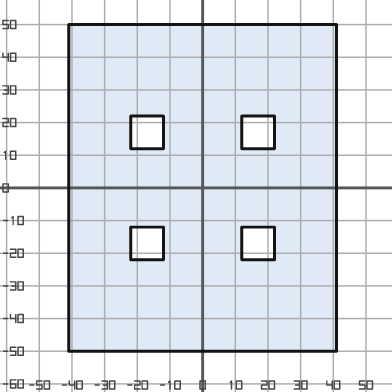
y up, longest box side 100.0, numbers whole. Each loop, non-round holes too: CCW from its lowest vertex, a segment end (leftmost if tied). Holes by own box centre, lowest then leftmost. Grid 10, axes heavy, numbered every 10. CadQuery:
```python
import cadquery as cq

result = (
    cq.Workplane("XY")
    .moveTo(-41.0, -50.0)
    .lineTo(41.0, -50.0)
    .lineTo(41.0, 50.0)
    .lineTo(-41.0, 50.0)
    .close()
    .moveTo(-22.0, -22.0)
    .lineTo(-12.0, -22.0)
    .lineTo(-12.0, -12.0)
    .lineTo(-22.0, -12.0)
    .close()
    .moveTo(12.0, -22.0)
    .lineTo(22.0, -22.0)
    .lineTo(22.0, -12.0)
    .lineTo(12.0, -12.0)
    .close()
    .moveTo(-22.0, 12.0)
    .lineTo(-12.0, 12.0)
    .lineTo(-12.0, 22.0)
    .lineTo(-22.0, 22.0)
    .close()
    .moveTo(12.0, 12.0)
    .lineTo(22.0, 12.0)
    .lineTo(22.0, 22.0)
    .lineTo(12.0, 22.0)
    .close()
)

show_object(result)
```